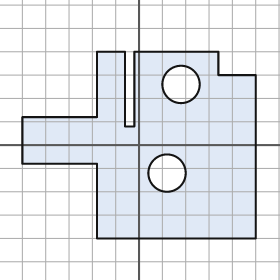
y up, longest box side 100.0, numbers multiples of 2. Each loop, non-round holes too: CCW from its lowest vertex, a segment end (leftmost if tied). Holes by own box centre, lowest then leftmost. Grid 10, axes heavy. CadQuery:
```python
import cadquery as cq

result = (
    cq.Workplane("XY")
    .moveTo(-18.0, -40.0)
    .lineTo(50.0, -40.0)
    .lineTo(50.0, 30.0)
    .lineTo(34.0, 30.0)
    .lineTo(34.0, 40.0)
    .lineTo(-2.0, 40.0)
    .lineTo(-2.0, 8.0)
    .lineTo(-6.0, 8.0)
    .lineTo(-6.0, 40.0)
    .lineTo(-18.0, 40.0)
    .lineTo(-18.0, 12.0)
    .lineTo(-50.0, 12.0)
    .lineTo(-50.0, -8.0)
    .lineTo(-18.0, -8.0)
    .close()
    .moveTo(12.0, -12.0)
    .circle(8.0)
    .moveTo(18.0, 26.0)
    .circle(8.0)
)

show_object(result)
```